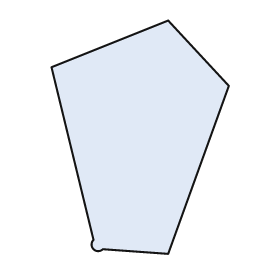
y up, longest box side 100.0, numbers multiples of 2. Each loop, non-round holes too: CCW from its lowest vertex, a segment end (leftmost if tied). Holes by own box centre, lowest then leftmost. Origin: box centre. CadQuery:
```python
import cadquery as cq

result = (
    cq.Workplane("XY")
    .moveTo(12.0, -50.0)
    .lineTo(38.0, 22.0)
    .lineTo(12.0, 50.0)
    .lineTo(-38.0, 30.0)
    .lineTo(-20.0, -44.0)
    .threePointArc((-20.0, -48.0), (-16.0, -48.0))
    .close()
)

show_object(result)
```